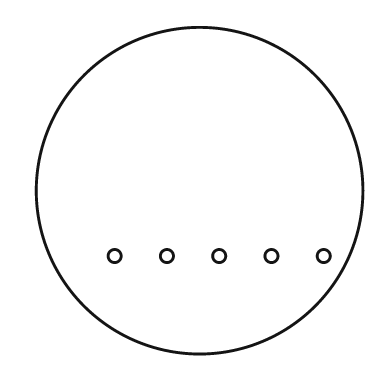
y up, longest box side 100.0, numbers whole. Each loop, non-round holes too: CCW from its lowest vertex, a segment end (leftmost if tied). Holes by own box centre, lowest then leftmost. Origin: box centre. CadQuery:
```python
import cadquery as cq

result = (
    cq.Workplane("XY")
    .moveTo(0.0, 0.0)
    .circle(50.0)
    .moveTo(-26.0, -20.0)
    .circle(2.0)
    .moveTo(-10.0, -20.0)
    .circle(2.0)
    .moveTo(6.0, -20.0)
    .circle(2.0)
    .moveTo(22.0, -20.0)
    .circle(2.0)
    .moveTo(38.0, -20.0)
    .circle(2.0)
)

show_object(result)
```